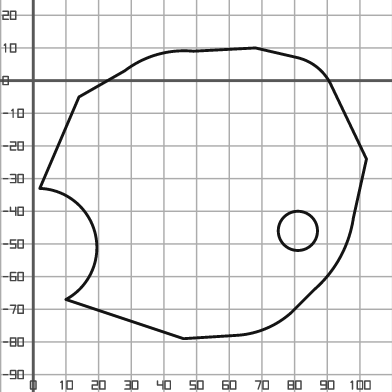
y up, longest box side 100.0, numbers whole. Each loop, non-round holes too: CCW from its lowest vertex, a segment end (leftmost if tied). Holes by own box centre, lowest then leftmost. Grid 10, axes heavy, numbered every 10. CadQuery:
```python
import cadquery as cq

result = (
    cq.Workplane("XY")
    .moveTo(46.0, -79.0)
    .lineTo(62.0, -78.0)
    .threePointArc((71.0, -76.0), (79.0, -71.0))
    .lineTo(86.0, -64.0)
    .threePointArc((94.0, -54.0), (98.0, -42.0))
    .lineTo(102.0, -24.0)
    .lineTo(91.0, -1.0)
    .threePointArc((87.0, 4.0), (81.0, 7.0))
    .lineTo(68.0, 10.0)
    .lineTo(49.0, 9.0)
    .threePointArc((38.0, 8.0), (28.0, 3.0))
    .lineTo(14.0, -5.0)
    .lineTo(2.0, -33.0)
    .threePointArc((19.0, -47.0), (10.0, -67.0))
    .close()
    .moveTo(81.0, -46.0)
    .circle(6.0)
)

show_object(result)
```